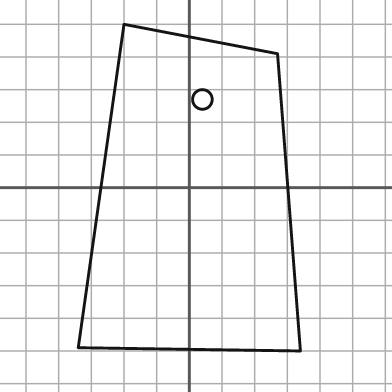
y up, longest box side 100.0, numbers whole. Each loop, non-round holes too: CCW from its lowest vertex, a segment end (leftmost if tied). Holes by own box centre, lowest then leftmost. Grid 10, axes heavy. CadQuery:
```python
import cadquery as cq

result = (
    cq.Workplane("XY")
    .moveTo(34.0, -50.0)
    .lineTo(27.0, 41.0)
    .lineTo(-20.0, 50.0)
    .lineTo(-34.0, -49.0)
    .close()
    .moveTo(4.0, 27.0)
    .circle(3.0)
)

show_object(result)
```